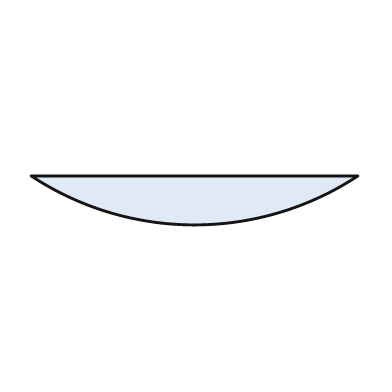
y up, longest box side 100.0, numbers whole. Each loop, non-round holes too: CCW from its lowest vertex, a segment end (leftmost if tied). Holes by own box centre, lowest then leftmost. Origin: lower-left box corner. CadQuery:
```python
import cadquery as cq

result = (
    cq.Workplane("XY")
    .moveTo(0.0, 15.0)
    .threePointArc((50.0, 0.0), (100.0, 15.0))
    .close()
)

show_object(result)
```